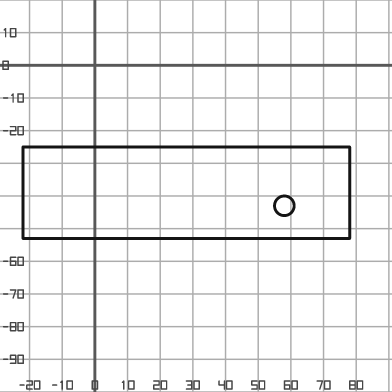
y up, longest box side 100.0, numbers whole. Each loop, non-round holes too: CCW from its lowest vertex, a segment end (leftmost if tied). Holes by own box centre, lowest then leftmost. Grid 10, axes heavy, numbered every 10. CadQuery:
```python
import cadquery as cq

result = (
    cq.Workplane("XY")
    .moveTo(-22.0, -53.0)
    .lineTo(78.0, -53.0)
    .lineTo(78.0, -25.0)
    .lineTo(-22.0, -25.0)
    .close()
    .moveTo(58.0, -43.0)
    .circle(3.0)
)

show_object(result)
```